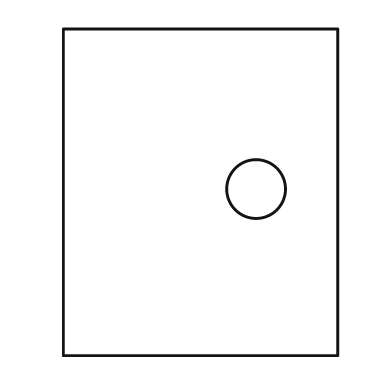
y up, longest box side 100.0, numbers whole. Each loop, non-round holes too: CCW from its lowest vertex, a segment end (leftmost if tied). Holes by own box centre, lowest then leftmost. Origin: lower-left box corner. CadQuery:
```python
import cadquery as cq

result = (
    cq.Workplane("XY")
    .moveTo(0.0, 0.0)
    .lineTo(84.0, 0.0)
    .lineTo(84.0, 100.0)
    .lineTo(0.0, 100.0)
    .close()
    .moveTo(59.0, 51.0)
    .circle(9.0)
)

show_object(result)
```